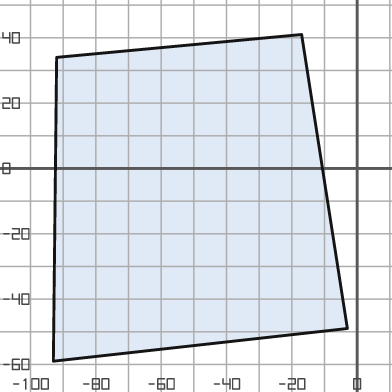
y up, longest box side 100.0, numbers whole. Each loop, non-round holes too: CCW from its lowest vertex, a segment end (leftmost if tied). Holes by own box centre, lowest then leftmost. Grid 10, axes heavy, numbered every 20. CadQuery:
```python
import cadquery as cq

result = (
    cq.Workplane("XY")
    .moveTo(-93.0, -59.0)
    .lineTo(-3.0, -49.0)
    .lineTo(-17.0, 41.0)
    .lineTo(-92.0, 34.0)
    .close()
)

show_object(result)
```